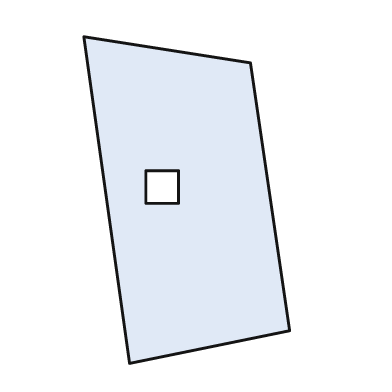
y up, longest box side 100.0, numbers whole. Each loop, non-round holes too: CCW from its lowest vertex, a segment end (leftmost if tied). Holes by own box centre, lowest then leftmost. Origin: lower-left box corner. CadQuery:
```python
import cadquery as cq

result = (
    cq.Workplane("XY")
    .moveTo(14.0, 0.0)
    .lineTo(63.0, 10.0)
    .lineTo(51.0, 92.0)
    .lineTo(0.0, 100.0)
    .close()
    .moveTo(19.0, 49.0)
    .lineTo(29.0, 49.0)
    .lineTo(29.0, 59.0)
    .lineTo(19.0, 59.0)
    .close()
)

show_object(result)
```